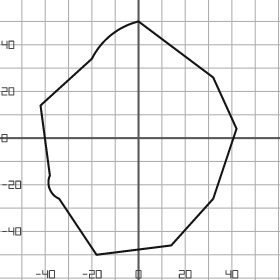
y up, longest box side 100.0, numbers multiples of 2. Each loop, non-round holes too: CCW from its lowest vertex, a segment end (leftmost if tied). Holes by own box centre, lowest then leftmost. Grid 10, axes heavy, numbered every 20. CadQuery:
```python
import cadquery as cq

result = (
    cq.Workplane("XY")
    .moveTo(-18.0, -50.0)
    .lineTo(14.0, -46.0)
    .lineTo(32.0, -26.0)
    .lineTo(42.0, 4.0)
    .lineTo(32.0, 26.0)
    .lineTo(0.0, 50.0)
    .threePointArc((-12.0, 44.0), (-20.0, 34.0))
    .lineTo(-42.0, 14.0)
    .lineTo(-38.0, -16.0)
    .threePointArc((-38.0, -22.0), (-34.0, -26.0))
    .close()
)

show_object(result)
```